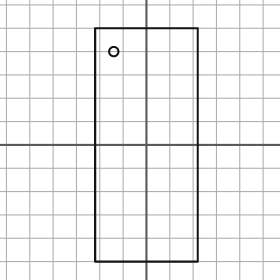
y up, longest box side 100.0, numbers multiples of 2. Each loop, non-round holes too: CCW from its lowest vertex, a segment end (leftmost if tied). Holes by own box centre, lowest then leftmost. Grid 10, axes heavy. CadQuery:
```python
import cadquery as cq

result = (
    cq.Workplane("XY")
    .moveTo(-22.0, -50.0)
    .lineTo(22.0, -50.0)
    .lineTo(22.0, 50.0)
    .lineTo(-22.0, 50.0)
    .close()
    .moveTo(-14.0, 40.0)
    .circle(2.0)
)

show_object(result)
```